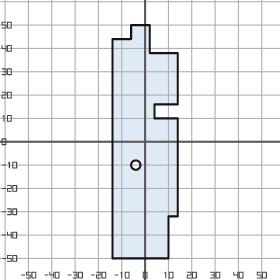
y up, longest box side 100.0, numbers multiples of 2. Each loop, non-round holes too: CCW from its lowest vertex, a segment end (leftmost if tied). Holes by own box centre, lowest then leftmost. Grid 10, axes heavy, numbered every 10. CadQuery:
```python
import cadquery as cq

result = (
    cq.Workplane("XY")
    .moveTo(-14.0, -50.0)
    .lineTo(10.0, -50.0)
    .lineTo(10.0, -32.0)
    .lineTo(14.0, -32.0)
    .lineTo(14.0, 10.0)
    .lineTo(4.0, 10.0)
    .lineTo(4.0, 16.0)
    .lineTo(14.0, 16.0)
    .lineTo(14.0, 38.0)
    .lineTo(2.0, 38.0)
    .lineTo(2.0, 50.0)
    .lineTo(-6.0, 50.0)
    .lineTo(-6.0, 44.0)
    .lineTo(-14.0, 44.0)
    .close()
    .moveTo(-4.0, -10.0)
    .circle(2.0)
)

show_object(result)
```